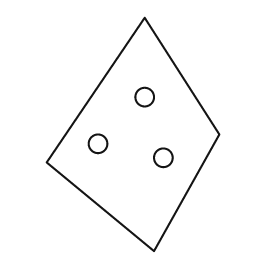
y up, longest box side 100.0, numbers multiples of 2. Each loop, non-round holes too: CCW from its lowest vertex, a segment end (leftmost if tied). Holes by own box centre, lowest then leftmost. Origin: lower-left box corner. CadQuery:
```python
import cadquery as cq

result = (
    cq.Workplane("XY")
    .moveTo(46.0, 0.0)
    .lineTo(74.0, 50.0)
    .lineTo(42.0, 100.0)
    .lineTo(0.0, 38.0)
    .close()
    .moveTo(50.0, 40.0)
    .circle(4.0)
    .moveTo(22.0, 46.0)
    .circle(4.0)
    .moveTo(42.0, 66.0)
    .circle(4.0)
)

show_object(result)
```